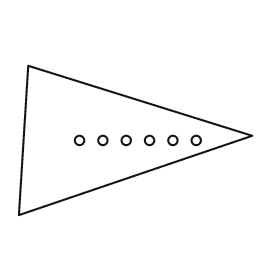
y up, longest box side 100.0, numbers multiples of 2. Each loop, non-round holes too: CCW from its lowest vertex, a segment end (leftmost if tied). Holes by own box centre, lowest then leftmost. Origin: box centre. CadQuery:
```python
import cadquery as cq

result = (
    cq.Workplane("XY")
    .moveTo(-50.0, -32.0)
    .lineTo(50.0, 2.0)
    .lineTo(-46.0, 32.0)
    .close()
    .moveTo(-24.0, 0.0)
    .circle(2.0)
    .moveTo(-14.0, 0.0)
    .circle(2.0)
    .moveTo(-4.0, 0.0)
    .circle(2.0)
    .moveTo(6.0, 0.0)
    .circle(2.0)
    .moveTo(16.0, 0.0)
    .circle(2.0)
    .moveTo(26.0, 0.0)
    .circle(2.0)
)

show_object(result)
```